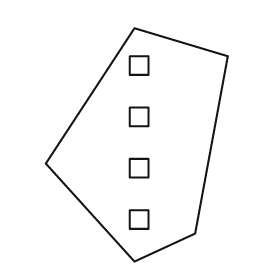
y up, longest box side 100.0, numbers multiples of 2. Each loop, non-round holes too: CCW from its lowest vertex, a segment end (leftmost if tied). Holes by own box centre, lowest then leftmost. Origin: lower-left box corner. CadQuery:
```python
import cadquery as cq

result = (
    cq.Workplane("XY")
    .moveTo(38.0, 0.0)
    .lineTo(64.0, 12.0)
    .lineTo(78.0, 88.0)
    .lineTo(38.0, 100.0)
    .lineTo(0.0, 42.0)
    .close()
    .moveTo(36.0, 14.0)
    .lineTo(44.0, 14.0)
    .lineTo(44.0, 22.0)
    .lineTo(36.0, 22.0)
    .close()
    .moveTo(36.0, 36.0)
    .lineTo(44.0, 36.0)
    .lineTo(44.0, 44.0)
    .lineTo(36.0, 44.0)
    .close()
    .moveTo(36.0, 58.0)
    .lineTo(44.0, 58.0)
    .lineTo(44.0, 66.0)
    .lineTo(36.0, 66.0)
    .close()
    .moveTo(36.0, 80.0)
    .lineTo(44.0, 80.0)
    .lineTo(44.0, 88.0)
    .lineTo(36.0, 88.0)
    .close()
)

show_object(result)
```